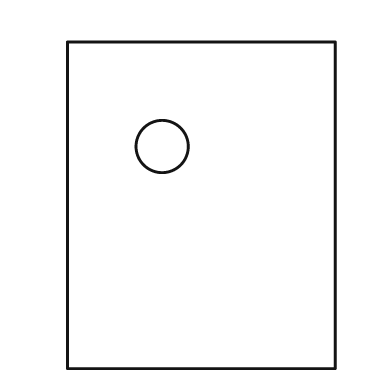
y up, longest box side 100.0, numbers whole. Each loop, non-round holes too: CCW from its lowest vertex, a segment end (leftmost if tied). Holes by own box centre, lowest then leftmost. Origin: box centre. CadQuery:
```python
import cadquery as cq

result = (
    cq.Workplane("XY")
    .moveTo(-41.0, -50.0)
    .lineTo(41.0, -50.0)
    .lineTo(41.0, 50.0)
    .lineTo(-41.0, 50.0)
    .close()
    .moveTo(-12.0, 18.0)
    .circle(8.0)
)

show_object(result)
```